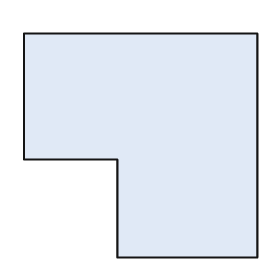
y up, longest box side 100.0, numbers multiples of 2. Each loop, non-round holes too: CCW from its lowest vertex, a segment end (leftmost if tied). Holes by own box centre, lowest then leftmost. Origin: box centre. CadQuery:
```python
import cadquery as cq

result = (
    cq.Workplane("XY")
    .moveTo(-10.0, -48.0)
    .lineTo(50.0, -48.0)
    .lineTo(50.0, 48.0)
    .lineTo(-50.0, 48.0)
    .lineTo(-50.0, -6.0)
    .lineTo(-10.0, -6.0)
    .close()
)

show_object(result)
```